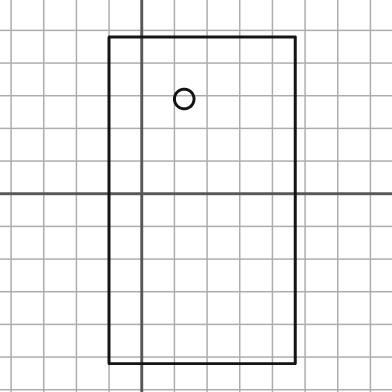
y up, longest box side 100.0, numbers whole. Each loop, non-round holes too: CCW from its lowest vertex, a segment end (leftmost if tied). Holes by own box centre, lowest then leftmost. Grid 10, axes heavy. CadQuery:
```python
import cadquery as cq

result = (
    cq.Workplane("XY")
    .moveTo(-10.0, -52.0)
    .lineTo(47.0, -52.0)
    .lineTo(47.0, 48.0)
    .lineTo(-10.0, 48.0)
    .close()
    .moveTo(13.0, 29.0)
    .circle(3.0)
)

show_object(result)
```